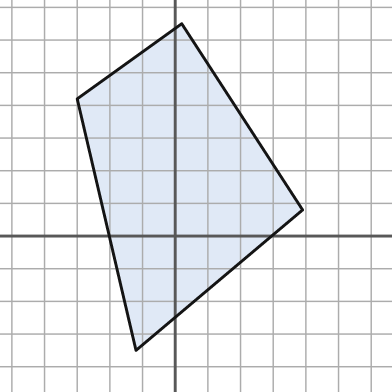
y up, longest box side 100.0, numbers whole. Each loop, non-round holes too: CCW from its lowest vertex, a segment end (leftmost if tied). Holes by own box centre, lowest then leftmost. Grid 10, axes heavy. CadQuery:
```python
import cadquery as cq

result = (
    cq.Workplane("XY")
    .moveTo(-12.0, -35.0)
    .lineTo(39.0, 8.0)
    .lineTo(2.0, 65.0)
    .lineTo(-30.0, 42.0)
    .close()
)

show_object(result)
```